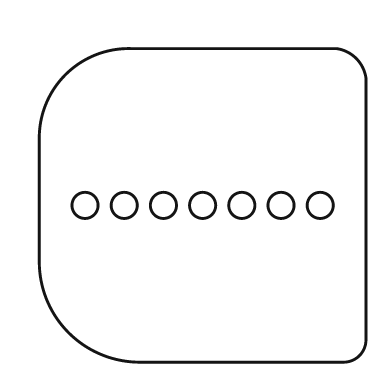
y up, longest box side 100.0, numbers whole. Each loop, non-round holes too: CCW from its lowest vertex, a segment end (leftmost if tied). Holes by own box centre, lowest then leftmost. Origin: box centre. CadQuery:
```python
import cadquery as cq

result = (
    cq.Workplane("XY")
    .moveTo(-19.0, -48.0)
    .lineTo(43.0, -48.0)
    .threePointArc((48.0, -46.0), (50.0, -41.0))
    .lineTo(50.0, 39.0)
    .threePointArc((47.0, 45.0), (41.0, 48.0))
    .lineTo(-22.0, 48.0)
    .threePointArc((-42.0, 40.0), (-50.0, 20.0))
    .lineTo(-50.0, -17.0)
    .threePointArc((-41.0, -39.0), (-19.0, -48.0))
    .close()
    .moveTo(-36.0, 0.0)
    .circle(4.0)
    .moveTo(-24.0, 0.0)
    .circle(4.0)
    .moveTo(-12.0, 0.0)
    .circle(4.0)
    .moveTo(0.0, 0.0)
    .circle(4.0)
    .moveTo(12.0, 0.0)
    .circle(4.0)
    .moveTo(24.0, 0.0)
    .circle(4.0)
    .moveTo(36.0, 0.0)
    .circle(4.0)
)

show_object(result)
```